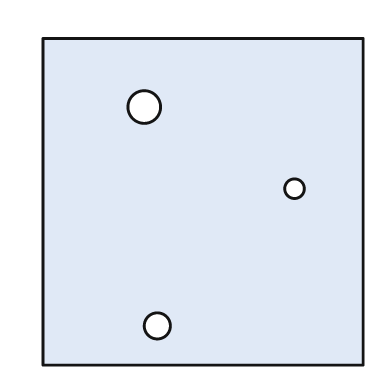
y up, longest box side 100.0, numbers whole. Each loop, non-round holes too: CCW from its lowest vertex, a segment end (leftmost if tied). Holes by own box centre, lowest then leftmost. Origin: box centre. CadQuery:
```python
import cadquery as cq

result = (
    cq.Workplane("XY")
    .moveTo(-49.0, -50.0)
    .lineTo(49.0, -50.0)
    .lineTo(49.0, 50.0)
    .lineTo(-49.0, 50.0)
    .close()
    .moveTo(-14.0, -38.0)
    .circle(4.0)
    .moveTo(28.0, 4.0)
    .circle(3.0)
    .moveTo(-18.0, 29.0)
    .circle(5.0)
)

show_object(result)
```